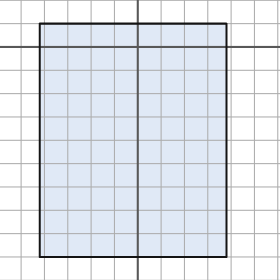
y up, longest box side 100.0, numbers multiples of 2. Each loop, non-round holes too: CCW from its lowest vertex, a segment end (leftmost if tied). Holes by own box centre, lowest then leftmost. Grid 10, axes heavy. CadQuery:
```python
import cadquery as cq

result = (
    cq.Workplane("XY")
    .moveTo(-42.0, -90.0)
    .lineTo(38.0, -90.0)
    .lineTo(38.0, 10.0)
    .lineTo(-42.0, 10.0)
    .close()
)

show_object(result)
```